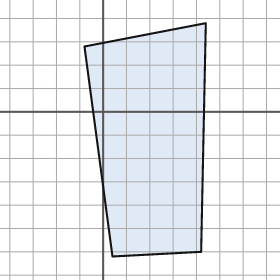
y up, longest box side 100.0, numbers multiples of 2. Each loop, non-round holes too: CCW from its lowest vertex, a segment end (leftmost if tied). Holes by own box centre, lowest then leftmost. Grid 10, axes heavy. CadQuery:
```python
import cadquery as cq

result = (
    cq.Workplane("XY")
    .moveTo(4.0, -62.0)
    .lineTo(42.0, -60.0)
    .lineTo(44.0, 38.0)
    .lineTo(-8.0, 28.0)
    .close()
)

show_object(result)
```